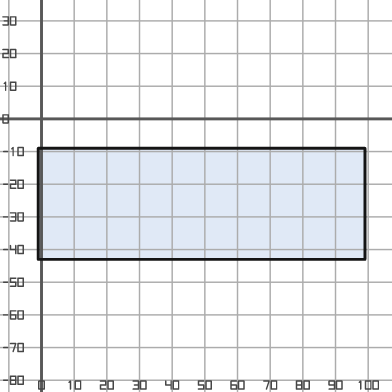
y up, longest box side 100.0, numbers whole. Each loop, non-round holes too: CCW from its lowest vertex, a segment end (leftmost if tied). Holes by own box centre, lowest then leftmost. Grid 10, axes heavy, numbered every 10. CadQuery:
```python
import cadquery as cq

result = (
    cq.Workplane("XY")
    .moveTo(-1.0, -43.0)
    .lineTo(99.0, -43.0)
    .lineTo(99.0, -9.0)
    .lineTo(-1.0, -9.0)
    .close()
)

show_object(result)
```